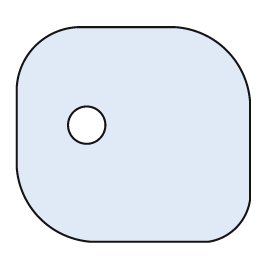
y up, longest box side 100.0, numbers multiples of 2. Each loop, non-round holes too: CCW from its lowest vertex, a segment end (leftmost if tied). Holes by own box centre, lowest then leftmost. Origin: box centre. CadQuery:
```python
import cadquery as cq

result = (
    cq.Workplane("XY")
    .moveTo(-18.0, -46.0)
    .lineTo(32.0, -46.0)
    .threePointArc((44.0, -40.0), (50.0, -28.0))
    .lineTo(50.0, 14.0)
    .threePointArc((40.0, 36.0), (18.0, 46.0))
    .lineTo(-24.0, 46.0)
    .threePointArc((-42.0, 38.0), (-50.0, 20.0))
    .lineTo(-50.0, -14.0)
    .threePointArc((-40.0, -36.0), (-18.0, -46.0))
    .close()
    .moveTo(-20.0, 4.0)
    .circle(8.0)
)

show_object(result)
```